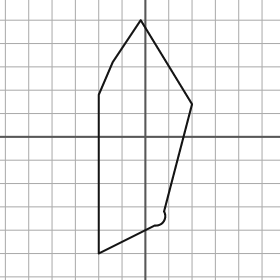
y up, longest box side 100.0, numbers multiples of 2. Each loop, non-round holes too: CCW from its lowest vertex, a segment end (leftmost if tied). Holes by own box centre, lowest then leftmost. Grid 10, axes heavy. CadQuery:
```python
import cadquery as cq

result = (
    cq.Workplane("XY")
    .moveTo(-20.0, -50.0)
    .lineTo(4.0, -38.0)
    .threePointArc((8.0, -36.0), (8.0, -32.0))
    .lineTo(20.0, 14.0)
    .lineTo(-2.0, 50.0)
    .lineTo(-14.0, 32.0)
    .lineTo(-20.0, 18.0)
    .close()
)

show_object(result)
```